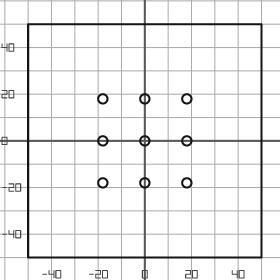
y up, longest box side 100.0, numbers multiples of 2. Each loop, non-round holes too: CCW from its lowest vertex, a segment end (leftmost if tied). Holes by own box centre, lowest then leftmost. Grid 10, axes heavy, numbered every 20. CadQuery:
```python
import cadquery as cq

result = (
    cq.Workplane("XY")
    .moveTo(-50.0, -50.0)
    .lineTo(50.0, -50.0)
    .lineTo(50.0, 50.0)
    .lineTo(-50.0, 50.0)
    .close()
    .moveTo(-18.0, -18.0)
    .circle(2.0)
    .moveTo(0.0, -18.0)
    .circle(2.0)
    .moveTo(18.0, -18.0)
    .circle(2.0)
    .moveTo(-18.0, 0.0)
    .circle(2.0)
    .moveTo(0.0, 0.0)
    .circle(2.0)
    .moveTo(18.0, 0.0)
    .circle(2.0)
    .moveTo(-18.0, 18.0)
    .circle(2.0)
    .moveTo(0.0, 18.0)
    .circle(2.0)
    .moveTo(18.0, 18.0)
    .circle(2.0)
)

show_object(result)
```